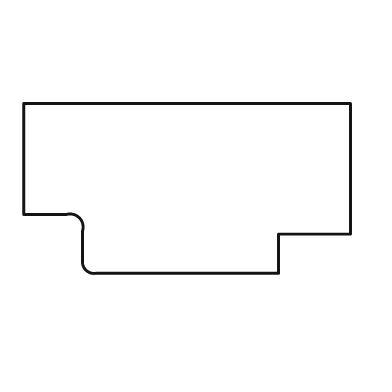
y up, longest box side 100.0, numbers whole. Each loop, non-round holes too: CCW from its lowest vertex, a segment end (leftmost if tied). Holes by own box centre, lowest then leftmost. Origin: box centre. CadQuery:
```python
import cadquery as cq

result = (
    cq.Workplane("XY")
    .moveTo(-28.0, -26.0)
    .lineTo(28.0, -26.0)
    .lineTo(28.0, -14.0)
    .lineTo(50.0, -14.0)
    .lineTo(50.0, 26.0)
    .lineTo(-50.0, 26.0)
    .lineTo(-50.0, -8.0)
    .lineTo(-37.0, -8.0)
    .threePointArc((-33.0, -9.0), (-32.0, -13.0))
    .lineTo(-32.0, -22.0)
    .threePointArc((-31.0, -25.0), (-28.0, -26.0))
    .close()
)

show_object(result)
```